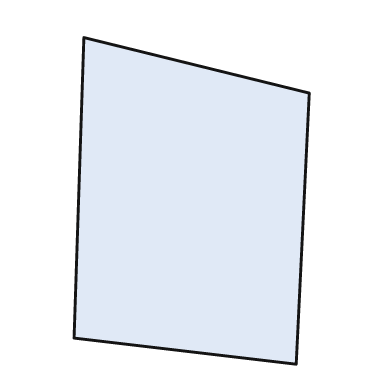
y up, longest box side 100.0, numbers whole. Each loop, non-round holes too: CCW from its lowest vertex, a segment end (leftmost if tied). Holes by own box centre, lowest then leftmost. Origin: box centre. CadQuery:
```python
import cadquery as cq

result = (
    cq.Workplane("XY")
    .moveTo(32.0, -50.0)
    .lineTo(36.0, 33.0)
    .lineTo(-33.0, 50.0)
    .lineTo(-36.0, -42.0)
    .close()
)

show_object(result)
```